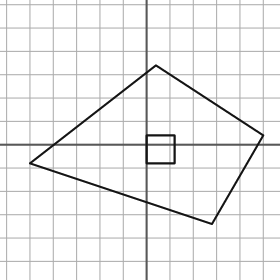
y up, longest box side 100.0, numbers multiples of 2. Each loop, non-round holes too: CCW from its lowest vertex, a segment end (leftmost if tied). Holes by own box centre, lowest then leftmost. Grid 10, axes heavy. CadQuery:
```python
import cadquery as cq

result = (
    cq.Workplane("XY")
    .moveTo(28.0, -34.0)
    .lineTo(50.0, 4.0)
    .lineTo(4.0, 34.0)
    .lineTo(-50.0, -8.0)
    .close()
    .moveTo(0.0, -8.0)
    .lineTo(12.0, -8.0)
    .lineTo(12.0, 4.0)
    .lineTo(0.0, 4.0)
    .close()
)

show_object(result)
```